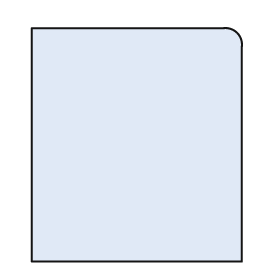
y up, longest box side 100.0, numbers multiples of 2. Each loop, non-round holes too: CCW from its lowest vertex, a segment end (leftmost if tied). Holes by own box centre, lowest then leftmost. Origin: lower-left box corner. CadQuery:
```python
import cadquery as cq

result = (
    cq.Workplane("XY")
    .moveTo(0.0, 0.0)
    .lineTo(90.0, 0.0)
    .lineTo(90.0, 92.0)
    .threePointArc((88.0, 98.0), (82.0, 100.0))
    .lineTo(0.0, 100.0)
    .close()
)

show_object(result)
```